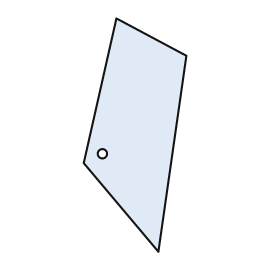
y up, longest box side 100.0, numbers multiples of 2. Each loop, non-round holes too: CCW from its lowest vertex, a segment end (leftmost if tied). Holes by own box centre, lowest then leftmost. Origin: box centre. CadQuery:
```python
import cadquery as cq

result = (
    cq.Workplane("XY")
    .moveTo(10.0, -50.0)
    .lineTo(22.0, 34.0)
    .lineTo(-8.0, 50.0)
    .lineTo(-22.0, -12.0)
    .close()
    .moveTo(-14.0, -8.0)
    .circle(2.0)
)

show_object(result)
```